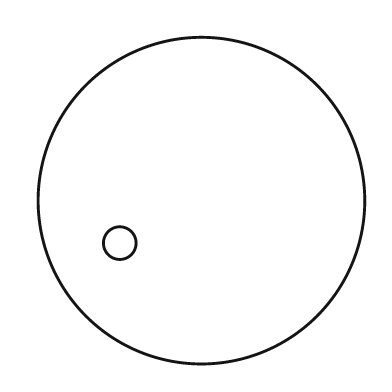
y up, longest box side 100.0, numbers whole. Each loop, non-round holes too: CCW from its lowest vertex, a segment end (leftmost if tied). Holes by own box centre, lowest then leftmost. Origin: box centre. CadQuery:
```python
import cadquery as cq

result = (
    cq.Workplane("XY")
    .moveTo(0.0, 0.0)
    .circle(50.0)
    .moveTo(-25.0, -13.0)
    .circle(5.0)
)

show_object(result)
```